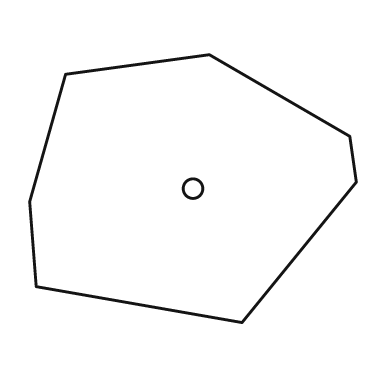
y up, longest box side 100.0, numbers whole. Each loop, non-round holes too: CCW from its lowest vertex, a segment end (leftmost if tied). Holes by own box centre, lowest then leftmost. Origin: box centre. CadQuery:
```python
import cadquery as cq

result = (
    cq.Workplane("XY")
    .moveTo(15.0, -41.0)
    .lineTo(50.0, 2.0)
    .lineTo(48.0, 16.0)
    .lineTo(5.0, 41.0)
    .lineTo(-39.0, 35.0)
    .lineTo(-50.0, -4.0)
    .lineTo(-48.0, -30.0)
    .close()
    .moveTo(0.0, 0.0)
    .circle(3.0)
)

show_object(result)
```